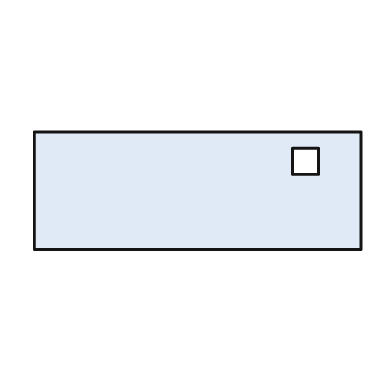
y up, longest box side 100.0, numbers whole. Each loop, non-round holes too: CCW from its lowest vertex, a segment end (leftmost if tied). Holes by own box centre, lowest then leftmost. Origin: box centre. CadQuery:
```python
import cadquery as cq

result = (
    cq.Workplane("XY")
    .moveTo(-50.0, -18.0)
    .lineTo(50.0, -18.0)
    .lineTo(50.0, 18.0)
    .lineTo(-50.0, 18.0)
    .close()
    .moveTo(29.0, 5.0)
    .lineTo(37.0, 5.0)
    .lineTo(37.0, 13.0)
    .lineTo(29.0, 13.0)
    .close()
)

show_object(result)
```